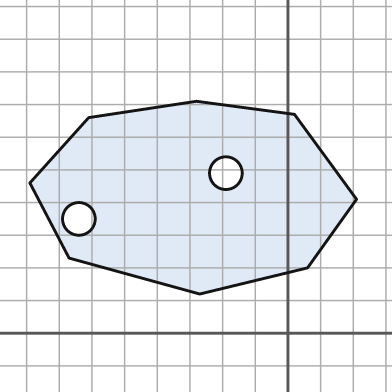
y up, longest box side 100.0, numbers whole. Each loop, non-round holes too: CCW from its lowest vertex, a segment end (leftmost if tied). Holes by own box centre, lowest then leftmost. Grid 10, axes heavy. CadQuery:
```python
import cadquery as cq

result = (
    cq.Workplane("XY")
    .moveTo(-27.0, 12.0)
    .lineTo(6.0, 20.0)
    .lineTo(21.0, 41.0)
    .lineTo(2.0, 67.0)
    .lineTo(-28.0, 71.0)
    .lineTo(-61.0, 66.0)
    .lineTo(-79.0, 46.0)
    .lineTo(-67.0, 23.0)
    .close()
    .moveTo(-64.0, 35.0)
    .circle(5.0)
    .moveTo(-19.0, 49.0)
    .circle(5.0)
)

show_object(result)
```